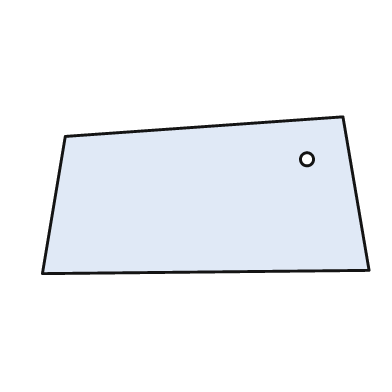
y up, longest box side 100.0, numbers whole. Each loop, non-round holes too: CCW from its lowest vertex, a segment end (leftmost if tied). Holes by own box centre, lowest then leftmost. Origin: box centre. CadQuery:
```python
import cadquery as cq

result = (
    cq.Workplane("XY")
    .moveTo(-50.0, -24.0)
    .lineTo(50.0, -23.0)
    .lineTo(42.0, 24.0)
    .lineTo(-43.0, 18.0)
    .close()
    .moveTo(31.0, 11.0)
    .circle(2.0)
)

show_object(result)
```